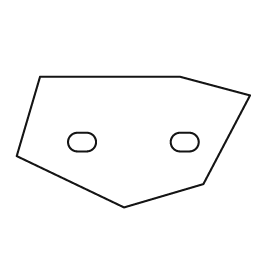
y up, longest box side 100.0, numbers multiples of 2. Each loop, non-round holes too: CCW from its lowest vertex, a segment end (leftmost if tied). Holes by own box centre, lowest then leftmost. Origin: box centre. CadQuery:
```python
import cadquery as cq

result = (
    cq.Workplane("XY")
    .moveTo(-4.0, -28.0)
    .lineTo(30.0, -18.0)
    .lineTo(50.0, 20.0)
    .lineTo(20.0, 28.0)
    .lineTo(-40.0, 28.0)
    .lineTo(-50.0, -6.0)
    .close()
    .moveTo(-24.0, -4.0)
    .lineTo(-20.0, -4.0)
    .threePointArc((-16.0, 0.0), (-20.0, 4.0))
    .lineTo(-24.0, 4.0)
    .threePointArc((-28.0, 0.0), (-24.0, -4.0))
    .close()
    .moveTo(20.0, -4.0)
    .lineTo(24.0, -4.0)
    .threePointArc((28.0, 0.0), (24.0, 4.0))
    .lineTo(20.0, 4.0)
    .threePointArc((16.0, 0.0), (20.0, -4.0))
    .close()
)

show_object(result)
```